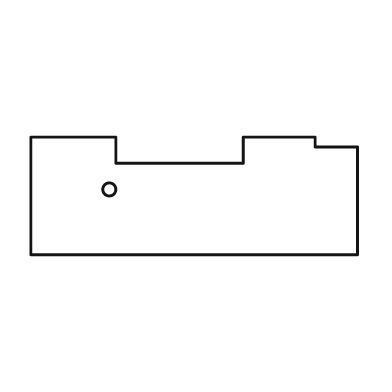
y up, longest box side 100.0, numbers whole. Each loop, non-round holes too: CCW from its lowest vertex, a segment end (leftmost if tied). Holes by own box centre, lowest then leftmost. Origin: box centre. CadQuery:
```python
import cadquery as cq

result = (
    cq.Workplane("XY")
    .moveTo(-50.0, -18.0)
    .lineTo(50.0, -18.0)
    .lineTo(50.0, 15.0)
    .lineTo(37.0, 15.0)
    .lineTo(37.0, 18.0)
    .lineTo(15.0, 18.0)
    .lineTo(15.0, 10.0)
    .lineTo(-24.0, 10.0)
    .lineTo(-24.0, 18.0)
    .lineTo(-50.0, 18.0)
    .close()
    .moveTo(-26.0, 2.0)
    .circle(2.0)
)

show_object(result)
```